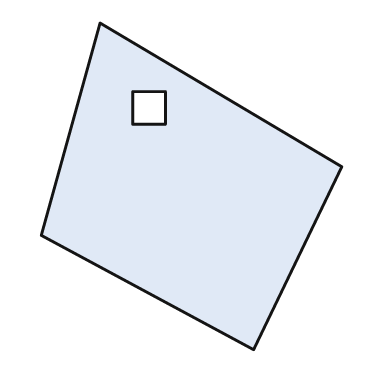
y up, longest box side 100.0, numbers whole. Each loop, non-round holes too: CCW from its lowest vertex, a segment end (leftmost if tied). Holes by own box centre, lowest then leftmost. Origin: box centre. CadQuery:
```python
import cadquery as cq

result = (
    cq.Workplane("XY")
    .moveTo(19.0, -50.0)
    .lineTo(46.0, 6.0)
    .lineTo(-28.0, 50.0)
    .lineTo(-46.0, -15.0)
    .close()
    .moveTo(-18.0, 19.0)
    .lineTo(-8.0, 19.0)
    .lineTo(-8.0, 29.0)
    .lineTo(-18.0, 29.0)
    .close()
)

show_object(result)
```